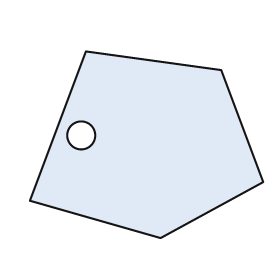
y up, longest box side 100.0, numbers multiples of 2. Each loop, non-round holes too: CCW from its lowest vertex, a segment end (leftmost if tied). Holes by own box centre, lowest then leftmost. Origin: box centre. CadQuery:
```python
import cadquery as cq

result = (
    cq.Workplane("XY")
    .moveTo(6.0, -40.0)
    .lineTo(50.0, -16.0)
    .lineTo(32.0, 32.0)
    .lineTo(-26.0, 40.0)
    .lineTo(-50.0, -24.0)
    .close()
    .moveTo(-28.0, 4.0)
    .circle(6.0)
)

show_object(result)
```